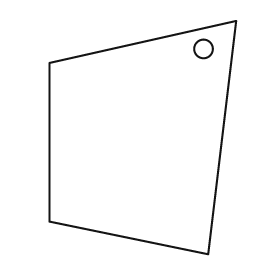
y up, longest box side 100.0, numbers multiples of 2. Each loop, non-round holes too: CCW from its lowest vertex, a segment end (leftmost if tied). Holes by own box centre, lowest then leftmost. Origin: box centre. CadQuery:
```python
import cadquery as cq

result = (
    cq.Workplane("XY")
    .moveTo(28.0, -50.0)
    .lineTo(40.0, 50.0)
    .lineTo(-40.0, 32.0)
    .lineTo(-40.0, -36.0)
    .close()
    .moveTo(26.0, 38.0)
    .circle(4.0)
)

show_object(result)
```